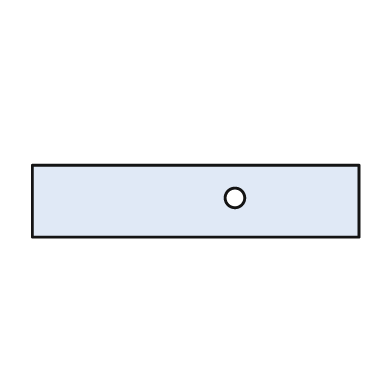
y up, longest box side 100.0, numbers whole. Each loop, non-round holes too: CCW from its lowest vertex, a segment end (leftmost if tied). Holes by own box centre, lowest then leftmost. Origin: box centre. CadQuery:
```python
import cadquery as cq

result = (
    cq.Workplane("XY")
    .moveTo(-50.0, -11.0)
    .lineTo(50.0, -11.0)
    .lineTo(50.0, 11.0)
    .lineTo(-50.0, 11.0)
    .close()
    .moveTo(12.0, 1.0)
    .circle(3.0)
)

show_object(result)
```